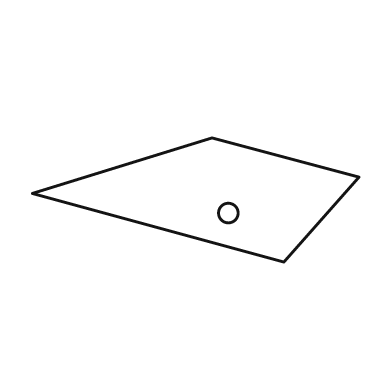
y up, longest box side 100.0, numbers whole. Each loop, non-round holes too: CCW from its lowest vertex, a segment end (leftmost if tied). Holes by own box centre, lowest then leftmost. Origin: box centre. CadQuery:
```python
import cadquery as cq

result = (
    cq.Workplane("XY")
    .moveTo(27.0, -19.0)
    .lineTo(50.0, 7.0)
    .lineTo(5.0, 19.0)
    .lineTo(-50.0, 2.0)
    .close()
    .moveTo(10.0, -4.0)
    .circle(3.0)
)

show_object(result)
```